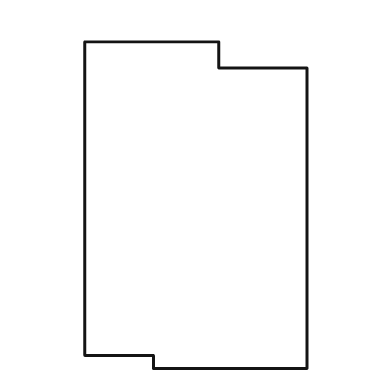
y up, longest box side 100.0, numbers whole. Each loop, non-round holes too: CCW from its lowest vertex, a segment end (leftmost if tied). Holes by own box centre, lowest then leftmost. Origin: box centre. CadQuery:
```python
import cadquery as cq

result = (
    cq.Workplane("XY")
    .moveTo(-13.0, -50.0)
    .lineTo(34.0, -50.0)
    .lineTo(34.0, 42.0)
    .lineTo(7.0, 42.0)
    .lineTo(7.0, 50.0)
    .lineTo(-34.0, 50.0)
    .lineTo(-34.0, -46.0)
    .lineTo(-13.0, -46.0)
    .close()
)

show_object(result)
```